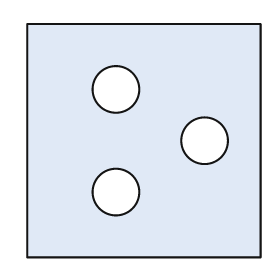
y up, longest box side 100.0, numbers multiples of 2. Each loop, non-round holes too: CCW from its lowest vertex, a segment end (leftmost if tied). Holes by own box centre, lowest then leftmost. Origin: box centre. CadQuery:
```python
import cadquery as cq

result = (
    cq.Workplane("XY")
    .moveTo(-50.0, -50.0)
    .lineTo(50.0, -50.0)
    .lineTo(50.0, 50.0)
    .lineTo(-50.0, 50.0)
    .close()
    .moveTo(-12.0, -22.0)
    .circle(10.0)
    .moveTo(26.0, 0.0)
    .circle(10.0)
    .moveTo(-12.0, 22.0)
    .circle(10.0)
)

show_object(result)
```